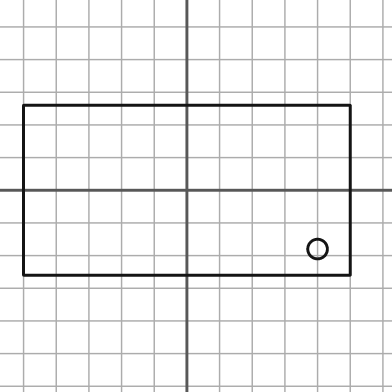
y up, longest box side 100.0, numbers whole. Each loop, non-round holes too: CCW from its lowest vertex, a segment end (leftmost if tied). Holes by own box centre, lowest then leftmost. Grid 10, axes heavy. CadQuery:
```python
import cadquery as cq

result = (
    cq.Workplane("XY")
    .moveTo(-50.0, -26.0)
    .lineTo(50.0, -26.0)
    .lineTo(50.0, 26.0)
    .lineTo(-50.0, 26.0)
    .close()
    .moveTo(40.0, -18.0)
    .circle(3.0)
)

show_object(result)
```